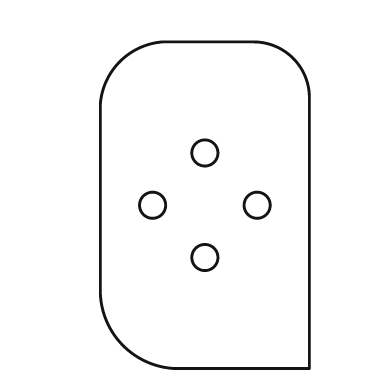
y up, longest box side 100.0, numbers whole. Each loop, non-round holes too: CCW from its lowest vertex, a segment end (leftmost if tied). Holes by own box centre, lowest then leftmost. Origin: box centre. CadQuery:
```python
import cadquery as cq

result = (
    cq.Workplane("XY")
    .moveTo(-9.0, -50.0)
    .lineTo(32.0, -50.0)
    .lineTo(32.0, 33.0)
    .threePointArc((27.0, 45.0), (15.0, 50.0))
    .lineTo(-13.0, 50.0)
    .threePointArc((-26.0, 44.0), (-32.0, 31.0))
    .lineTo(-32.0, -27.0)
    .threePointArc((-25.0, -43.0), (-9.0, -50.0))
    .close()
    .moveTo(0.0, -16.0)
    .circle(4.0)
    .moveTo(-16.0, 0.0)
    .circle(4.0)
    .moveTo(16.0, 0.0)
    .circle(4.0)
    .moveTo(0.0, 16.0)
    .circle(4.0)
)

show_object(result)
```